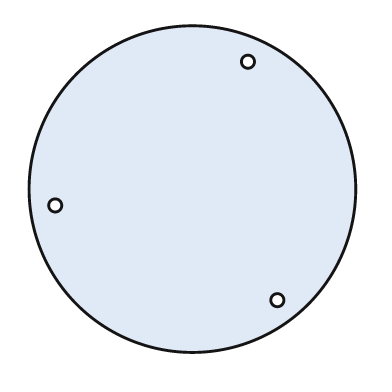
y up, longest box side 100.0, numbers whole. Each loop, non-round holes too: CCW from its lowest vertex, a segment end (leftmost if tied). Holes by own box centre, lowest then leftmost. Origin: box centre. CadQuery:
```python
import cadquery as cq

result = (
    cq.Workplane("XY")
    .moveTo(0.0, 0.0)
    .circle(50.0)
    .moveTo(26.0, -34.0)
    .circle(2.0)
    .moveTo(-42.0, -5.0)
    .circle(2.0)
    .moveTo(17.0, 39.0)
    .circle(2.0)
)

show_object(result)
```